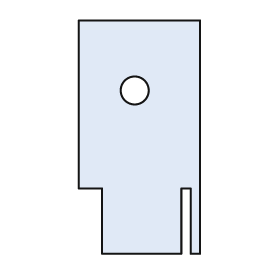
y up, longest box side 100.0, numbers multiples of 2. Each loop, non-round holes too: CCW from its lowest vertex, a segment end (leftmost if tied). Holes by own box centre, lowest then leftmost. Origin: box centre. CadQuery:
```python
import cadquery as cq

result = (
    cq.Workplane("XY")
    .moveTo(-16.0, -50.0)
    .lineTo(18.0, -50.0)
    .lineTo(18.0, -22.0)
    .lineTo(22.0, -22.0)
    .lineTo(22.0, -50.0)
    .lineTo(26.0, -50.0)
    .lineTo(26.0, 50.0)
    .lineTo(-26.0, 50.0)
    .lineTo(-26.0, -22.0)
    .lineTo(-16.0, -22.0)
    .close()
    .moveTo(-2.0, 20.0)
    .circle(6.0)
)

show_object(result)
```